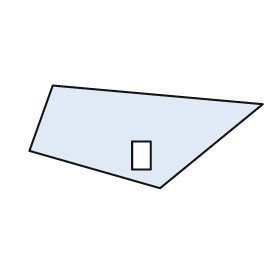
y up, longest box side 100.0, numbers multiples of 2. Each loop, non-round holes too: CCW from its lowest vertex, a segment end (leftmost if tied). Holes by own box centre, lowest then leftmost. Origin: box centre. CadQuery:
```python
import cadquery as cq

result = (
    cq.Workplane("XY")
    .moveTo(6.0, -22.0)
    .lineTo(50.0, 14.0)
    .lineTo(-40.0, 22.0)
    .lineTo(-50.0, -6.0)
    .close()
    .moveTo(-6.0, -14.0)
    .lineTo(2.0, -14.0)
    .lineTo(2.0, -2.0)
    .lineTo(-6.0, -2.0)
    .close()
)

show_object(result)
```